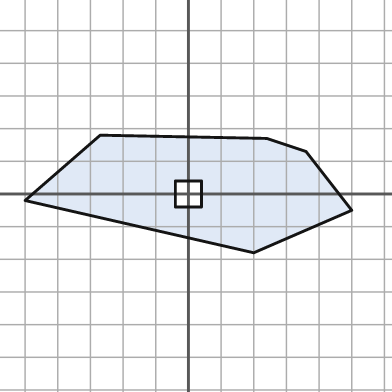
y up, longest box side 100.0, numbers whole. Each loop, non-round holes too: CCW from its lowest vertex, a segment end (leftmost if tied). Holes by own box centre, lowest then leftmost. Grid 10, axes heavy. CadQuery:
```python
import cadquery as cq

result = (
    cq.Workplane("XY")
    .moveTo(20.0, -18.0)
    .lineTo(50.0, -5.0)
    .lineTo(36.0, 13.0)
    .lineTo(24.0, 17.0)
    .lineTo(-27.0, 18.0)
    .lineTo(-50.0, -2.0)
    .close()
    .moveTo(-4.0, -4.0)
    .lineTo(4.0, -4.0)
    .lineTo(4.0, 4.0)
    .lineTo(-4.0, 4.0)
    .close()
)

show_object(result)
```